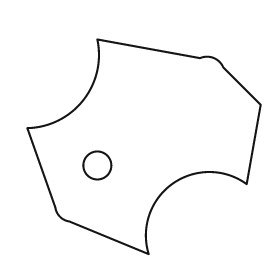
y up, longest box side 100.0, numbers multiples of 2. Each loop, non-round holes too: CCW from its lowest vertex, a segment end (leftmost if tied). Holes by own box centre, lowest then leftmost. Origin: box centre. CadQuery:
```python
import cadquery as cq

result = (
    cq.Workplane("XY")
    .moveTo(2.0, -46.0)
    .threePointArc((12.0, -16.0), (44.0, -16.0))
    .lineTo(50.0, 18.0)
    .lineTo(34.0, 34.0)
    .threePointArc((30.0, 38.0), (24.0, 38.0))
    .lineTo(-20.0, 46.0)
    .threePointArc((-26.0, 20.0), (-50.0, 8.0))
    .lineTo(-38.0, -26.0)
    .threePointArc((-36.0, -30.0), (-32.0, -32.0))
    .close()
    .moveTo(-20.0, -8.0)
    .circle(6.0)
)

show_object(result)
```